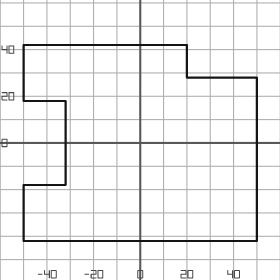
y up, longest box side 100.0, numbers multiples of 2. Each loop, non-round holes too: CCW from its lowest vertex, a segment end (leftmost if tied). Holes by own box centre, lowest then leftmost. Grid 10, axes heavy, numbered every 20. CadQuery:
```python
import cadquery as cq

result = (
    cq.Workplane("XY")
    .moveTo(-50.0, -42.0)
    .lineTo(50.0, -42.0)
    .lineTo(50.0, 28.0)
    .lineTo(20.0, 28.0)
    .lineTo(20.0, 42.0)
    .lineTo(-50.0, 42.0)
    .lineTo(-50.0, 18.0)
    .lineTo(-32.0, 18.0)
    .lineTo(-32.0, -18.0)
    .lineTo(-50.0, -18.0)
    .close()
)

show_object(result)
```